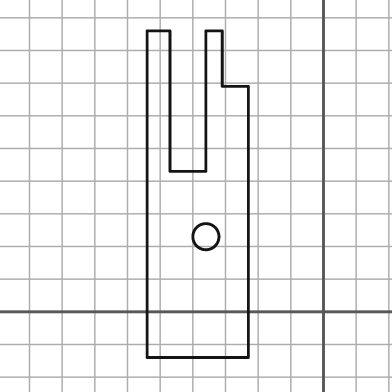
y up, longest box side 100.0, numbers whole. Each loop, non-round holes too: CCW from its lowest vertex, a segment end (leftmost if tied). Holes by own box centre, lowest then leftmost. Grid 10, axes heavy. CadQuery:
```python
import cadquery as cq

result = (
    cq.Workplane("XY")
    .moveTo(-54.0, -14.0)
    .lineTo(-23.0, -14.0)
    .lineTo(-23.0, 69.0)
    .lineTo(-31.0, 69.0)
    .lineTo(-31.0, 86.0)
    .lineTo(-36.0, 86.0)
    .lineTo(-36.0, 43.0)
    .lineTo(-47.0, 43.0)
    .lineTo(-47.0, 86.0)
    .lineTo(-54.0, 86.0)
    .close()
    .moveTo(-36.0, 23.0)
    .circle(4.0)
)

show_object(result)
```